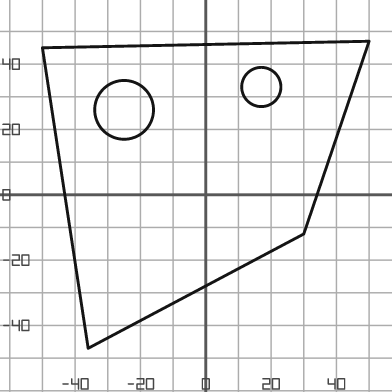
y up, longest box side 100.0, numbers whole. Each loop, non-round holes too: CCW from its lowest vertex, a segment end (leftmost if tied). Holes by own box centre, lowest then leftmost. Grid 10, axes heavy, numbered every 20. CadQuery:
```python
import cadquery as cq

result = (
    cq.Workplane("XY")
    .moveTo(-36.0, -47.0)
    .lineTo(30.0, -12.0)
    .lineTo(50.0, 47.0)
    .lineTo(-50.0, 45.0)
    .close()
    .moveTo(-25.0, 26.0)
    .circle(9.0)
    .moveTo(17.0, 33.0)
    .circle(6.0)
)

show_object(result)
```